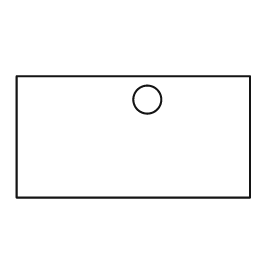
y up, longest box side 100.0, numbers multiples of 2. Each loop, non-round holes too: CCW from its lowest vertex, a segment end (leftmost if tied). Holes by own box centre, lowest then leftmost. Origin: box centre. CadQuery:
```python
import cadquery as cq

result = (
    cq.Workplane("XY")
    .moveTo(-50.0, -26.0)
    .lineTo(50.0, -26.0)
    .lineTo(50.0, 26.0)
    .lineTo(-50.0, 26.0)
    .close()
    .moveTo(6.0, 16.0)
    .circle(6.0)
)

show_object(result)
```